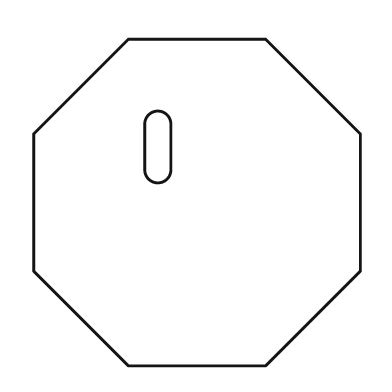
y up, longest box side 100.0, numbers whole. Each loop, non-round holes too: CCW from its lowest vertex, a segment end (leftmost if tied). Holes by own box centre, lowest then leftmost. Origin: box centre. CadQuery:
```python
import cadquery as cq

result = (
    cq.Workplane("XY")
    .moveTo(-21.0, -50.0)
    .lineTo(21.0, -50.0)
    .lineTo(50.0, -21.0)
    .lineTo(50.0, 21.0)
    .lineTo(21.0, 50.0)
    .lineTo(-21.0, 50.0)
    .lineTo(-50.0, 21.0)
    .lineTo(-50.0, -21.0)
    .close()
    .moveTo(-16.0, 10.0)
    .threePointArc((-12.0, 6.0), (-8.0, 10.0))
    .lineTo(-8.0, 24.0)
    .threePointArc((-12.0, 28.0), (-16.0, 24.0))
    .close()
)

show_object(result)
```